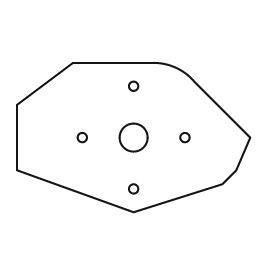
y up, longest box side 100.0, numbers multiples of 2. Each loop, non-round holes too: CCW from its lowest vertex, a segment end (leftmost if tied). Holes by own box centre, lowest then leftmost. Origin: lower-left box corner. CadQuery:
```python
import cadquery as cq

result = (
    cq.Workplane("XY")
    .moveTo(50.0, 0.0)
    .lineTo(88.0, 12.0)
    .lineTo(94.0, 18.0)
    .lineTo(100.0, 32.0)
    .lineTo(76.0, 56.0)
    .threePointArc((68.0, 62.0), (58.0, 64.0))
    .lineTo(24.0, 64.0)
    .lineTo(0.0, 46.0)
    .lineTo(0.0, 18.0)
    .close()
    .moveTo(50.0, 10.0)
    .circle(2.0)
    .moveTo(28.0, 32.0)
    .circle(2.0)
    .moveTo(50.0, 32.0)
    .circle(6.0)
    .moveTo(72.0, 32.0)
    .circle(2.0)
    .moveTo(50.0, 54.0)
    .circle(2.0)
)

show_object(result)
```